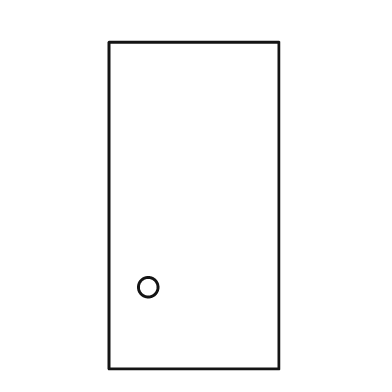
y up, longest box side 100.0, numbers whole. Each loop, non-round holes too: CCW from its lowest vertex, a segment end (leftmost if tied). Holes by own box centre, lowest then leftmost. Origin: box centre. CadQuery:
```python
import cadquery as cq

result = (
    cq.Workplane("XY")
    .moveTo(-26.0, -50.0)
    .lineTo(26.0, -50.0)
    .lineTo(26.0, 50.0)
    .lineTo(-26.0, 50.0)
    .close()
    .moveTo(-14.0, -25.0)
    .circle(3.0)
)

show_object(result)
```